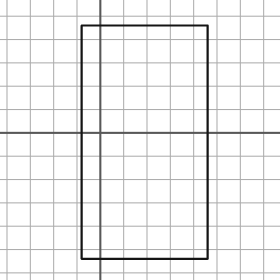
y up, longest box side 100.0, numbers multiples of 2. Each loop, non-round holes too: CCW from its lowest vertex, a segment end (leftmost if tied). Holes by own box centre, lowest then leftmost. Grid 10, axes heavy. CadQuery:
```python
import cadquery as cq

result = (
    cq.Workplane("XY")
    .moveTo(-8.0, -54.0)
    .lineTo(46.0, -54.0)
    .lineTo(46.0, 46.0)
    .lineTo(-8.0, 46.0)
    .close()
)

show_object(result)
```